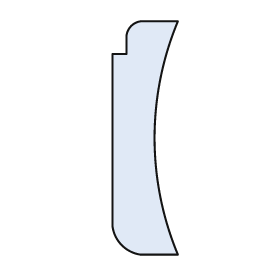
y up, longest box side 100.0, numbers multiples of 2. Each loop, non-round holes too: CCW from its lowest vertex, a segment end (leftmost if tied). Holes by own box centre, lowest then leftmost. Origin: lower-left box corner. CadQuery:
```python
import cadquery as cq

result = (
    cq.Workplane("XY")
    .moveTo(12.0, 0.0)
    .lineTo(28.0, 0.0)
    .threePointArc((18.0, 50.0), (28.0, 100.0))
    .lineTo(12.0, 100.0)
    .threePointArc((8.0, 98.0), (6.0, 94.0))
    .lineTo(6.0, 86.0)
    .lineTo(0.0, 86.0)
    .lineTo(0.0, 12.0)
    .threePointArc((4.0, 4.0), (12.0, 0.0))
    .close()
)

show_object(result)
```